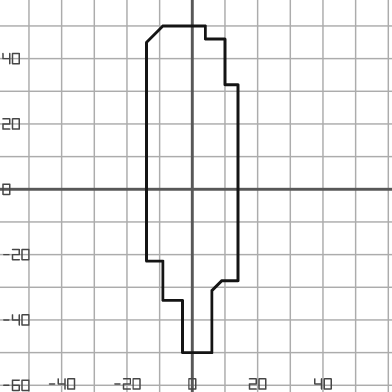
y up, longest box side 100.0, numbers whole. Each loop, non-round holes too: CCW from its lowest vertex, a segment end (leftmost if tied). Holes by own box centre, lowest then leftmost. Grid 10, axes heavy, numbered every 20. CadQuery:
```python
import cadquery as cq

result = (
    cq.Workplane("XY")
    .moveTo(-3.0, -50.0)
    .lineTo(6.0, -50.0)
    .lineTo(6.0, -31.0)
    .lineTo(9.0, -28.0)
    .lineTo(14.0, -28.0)
    .lineTo(14.0, 32.0)
    .lineTo(10.0, 32.0)
    .lineTo(10.0, 46.0)
    .lineTo(4.0, 46.0)
    .lineTo(4.0, 50.0)
    .lineTo(-9.0, 50.0)
    .lineTo(-14.0, 45.0)
    .lineTo(-14.0, -22.0)
    .lineTo(-9.0, -22.0)
    .lineTo(-9.0, -34.0)
    .lineTo(-3.0, -34.0)
    .close()
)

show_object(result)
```